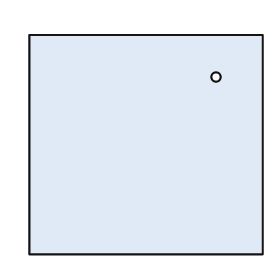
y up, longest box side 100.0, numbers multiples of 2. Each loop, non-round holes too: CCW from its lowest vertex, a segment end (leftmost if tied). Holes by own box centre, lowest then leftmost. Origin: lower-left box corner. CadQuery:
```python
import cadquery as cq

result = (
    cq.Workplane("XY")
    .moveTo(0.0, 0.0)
    .lineTo(100.0, 0.0)
    .lineTo(100.0, 94.0)
    .lineTo(0.0, 94.0)
    .close()
    .moveTo(80.0, 76.0)
    .circle(2.0)
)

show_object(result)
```